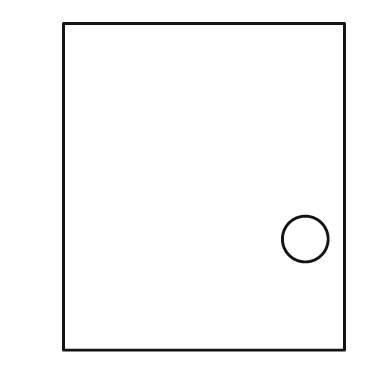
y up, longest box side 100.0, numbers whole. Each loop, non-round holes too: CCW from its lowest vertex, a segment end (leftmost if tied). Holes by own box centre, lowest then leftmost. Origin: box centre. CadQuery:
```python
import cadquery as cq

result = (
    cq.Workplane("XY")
    .moveTo(-43.0, -50.0)
    .lineTo(43.0, -50.0)
    .lineTo(43.0, 50.0)
    .lineTo(-43.0, 50.0)
    .close()
    .moveTo(31.0, -16.0)
    .circle(7.0)
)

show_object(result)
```